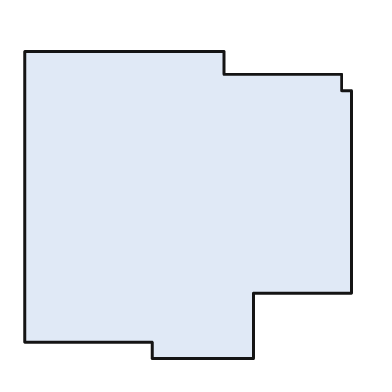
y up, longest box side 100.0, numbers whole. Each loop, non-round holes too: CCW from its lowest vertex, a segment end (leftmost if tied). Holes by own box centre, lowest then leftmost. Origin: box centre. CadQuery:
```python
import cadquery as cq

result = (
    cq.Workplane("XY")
    .moveTo(-11.0, -47.0)
    .lineTo(20.0, -47.0)
    .lineTo(20.0, -27.0)
    .lineTo(50.0, -27.0)
    .lineTo(50.0, 35.0)
    .lineTo(47.0, 35.0)
    .lineTo(47.0, 40.0)
    .lineTo(11.0, 40.0)
    .lineTo(11.0, 47.0)
    .lineTo(-50.0, 47.0)
    .lineTo(-50.0, -42.0)
    .lineTo(-11.0, -42.0)
    .close()
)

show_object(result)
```